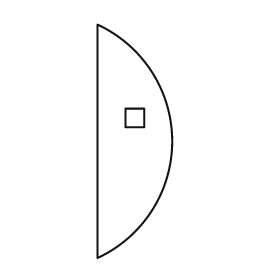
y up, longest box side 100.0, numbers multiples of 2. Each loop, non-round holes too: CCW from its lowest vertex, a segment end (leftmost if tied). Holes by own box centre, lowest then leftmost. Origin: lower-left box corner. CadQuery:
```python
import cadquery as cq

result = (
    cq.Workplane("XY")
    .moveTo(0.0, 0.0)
    .threePointArc((32.0, 50.0), (0.0, 100.0))
    .close()
    .moveTo(12.0, 56.0)
    .lineTo(20.0, 56.0)
    .lineTo(20.0, 64.0)
    .lineTo(12.0, 64.0)
    .close()
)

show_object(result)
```